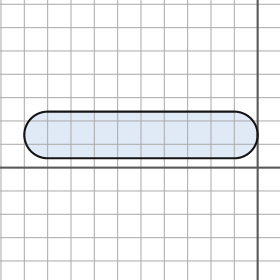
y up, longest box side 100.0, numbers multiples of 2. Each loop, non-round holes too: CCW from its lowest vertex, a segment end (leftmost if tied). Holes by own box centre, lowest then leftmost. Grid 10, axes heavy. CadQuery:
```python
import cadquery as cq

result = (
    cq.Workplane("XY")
    .moveTo(-90.0, 4.0)
    .lineTo(-10.0, 4.0)
    .threePointArc((0.0, 14.0), (-10.0, 24.0))
    .lineTo(-90.0, 24.0)
    .threePointArc((-100.0, 14.0), (-90.0, 4.0))
    .close()
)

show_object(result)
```